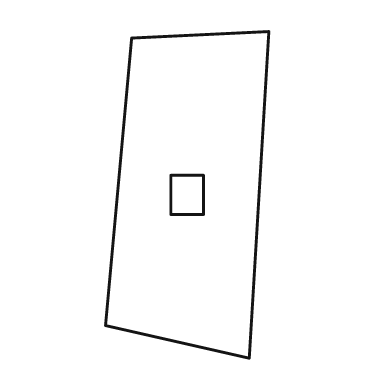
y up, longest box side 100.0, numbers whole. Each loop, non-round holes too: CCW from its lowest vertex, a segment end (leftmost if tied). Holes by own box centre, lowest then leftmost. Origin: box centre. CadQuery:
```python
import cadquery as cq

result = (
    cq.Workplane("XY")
    .moveTo(19.0, -50.0)
    .lineTo(25.0, 50.0)
    .lineTo(-17.0, 48.0)
    .lineTo(-25.0, -40.0)
    .close()
    .moveTo(-5.0, -6.0)
    .lineTo(5.0, -6.0)
    .lineTo(5.0, 6.0)
    .lineTo(-5.0, 6.0)
    .close()
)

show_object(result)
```